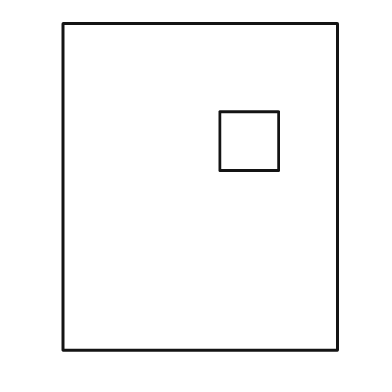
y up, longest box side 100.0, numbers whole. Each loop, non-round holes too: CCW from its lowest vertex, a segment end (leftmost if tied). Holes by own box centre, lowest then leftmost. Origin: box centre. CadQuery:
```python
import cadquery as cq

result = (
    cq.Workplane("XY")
    .moveTo(-42.0, -50.0)
    .lineTo(42.0, -50.0)
    .lineTo(42.0, 50.0)
    .lineTo(-42.0, 50.0)
    .close()
    .moveTo(6.0, 5.0)
    .lineTo(24.0, 5.0)
    .lineTo(24.0, 23.0)
    .lineTo(6.0, 23.0)
    .close()
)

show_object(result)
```